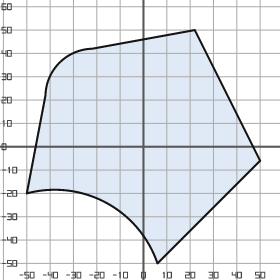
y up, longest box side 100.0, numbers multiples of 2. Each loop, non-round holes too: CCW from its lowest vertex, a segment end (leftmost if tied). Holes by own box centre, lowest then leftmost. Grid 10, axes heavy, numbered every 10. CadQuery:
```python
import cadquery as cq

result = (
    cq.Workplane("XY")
    .moveTo(6.0, -50.0)
    .lineTo(50.0, -6.0)
    .lineTo(22.0, 50.0)
    .lineTo(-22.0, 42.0)
    .threePointArc((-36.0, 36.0), (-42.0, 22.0))
    .lineTo(-50.0, -20.0)
    .threePointArc((-16.0, -24.0), (6.0, -50.0))
    .close()
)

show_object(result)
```